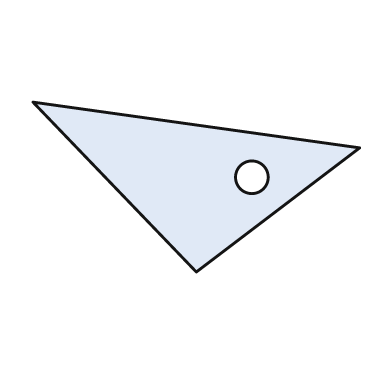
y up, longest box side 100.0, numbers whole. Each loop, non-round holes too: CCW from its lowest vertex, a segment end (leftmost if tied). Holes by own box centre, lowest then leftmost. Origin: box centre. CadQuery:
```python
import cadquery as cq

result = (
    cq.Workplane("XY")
    .moveTo(0.0, -26.0)
    .lineTo(50.0, 12.0)
    .lineTo(-50.0, 26.0)
    .close()
    .moveTo(17.0, 3.0)
    .circle(5.0)
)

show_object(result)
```